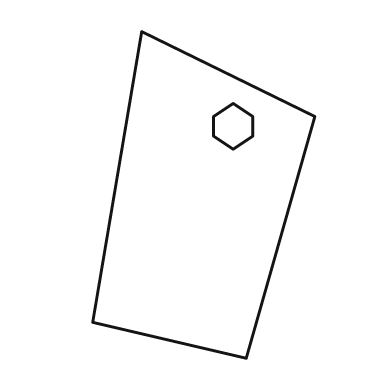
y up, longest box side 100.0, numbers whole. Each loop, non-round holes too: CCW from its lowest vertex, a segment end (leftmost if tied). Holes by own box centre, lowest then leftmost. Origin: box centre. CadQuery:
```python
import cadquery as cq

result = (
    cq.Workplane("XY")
    .moveTo(13.0, -50.0)
    .lineTo(34.0, 24.0)
    .lineTo(-19.0, 50.0)
    .lineTo(-34.0, -39.0)
    .close()
    .moveTo(9.0, 14.0)
    .lineTo(15.0, 18.0)
    .lineTo(15.0, 24.0)
    .lineTo(9.0, 28.0)
    .lineTo(3.0, 24.0)
    .lineTo(3.0, 18.0)
    .close()
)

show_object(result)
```